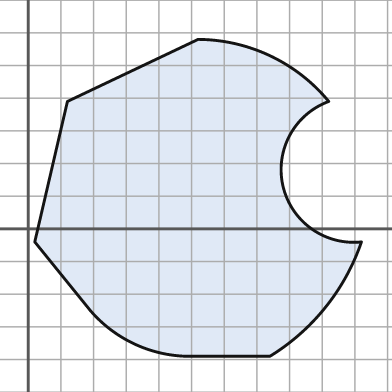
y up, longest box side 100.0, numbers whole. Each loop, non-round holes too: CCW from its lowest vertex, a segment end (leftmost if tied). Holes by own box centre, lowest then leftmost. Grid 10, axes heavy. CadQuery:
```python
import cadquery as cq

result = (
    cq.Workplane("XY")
    .moveTo(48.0, -39.0)
    .lineTo(74.0, -39.0)
    .threePointArc((91.0, -24.0), (102.0, -4.0))
    .threePointArc((78.0, 13.0), (92.0, 39.0))
    .threePointArc((74.0, 53.0), (52.0, 58.0))
    .lineTo(12.0, 39.0)
    .lineTo(2.0, -4.0)
    .lineTo(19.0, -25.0)
    .threePointArc((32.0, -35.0), (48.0, -39.0))
    .close()
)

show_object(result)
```